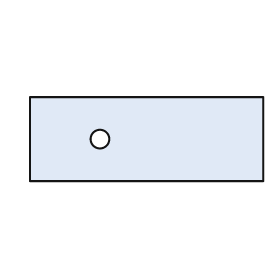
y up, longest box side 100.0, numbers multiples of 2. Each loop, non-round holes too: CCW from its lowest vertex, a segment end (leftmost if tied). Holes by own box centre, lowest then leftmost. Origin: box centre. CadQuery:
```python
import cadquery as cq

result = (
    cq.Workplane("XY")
    .moveTo(-50.0, -18.0)
    .lineTo(50.0, -18.0)
    .lineTo(50.0, 18.0)
    .lineTo(-50.0, 18.0)
    .close()
    .moveTo(-20.0, 0.0)
    .circle(4.0)
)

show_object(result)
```